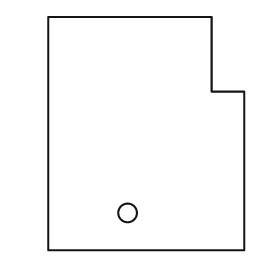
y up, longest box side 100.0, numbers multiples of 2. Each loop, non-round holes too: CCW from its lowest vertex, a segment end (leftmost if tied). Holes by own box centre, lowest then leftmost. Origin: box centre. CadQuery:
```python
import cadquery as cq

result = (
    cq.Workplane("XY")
    .moveTo(-42.0, -50.0)
    .lineTo(42.0, -50.0)
    .lineTo(42.0, 18.0)
    .lineTo(28.0, 18.0)
    .lineTo(28.0, 50.0)
    .lineTo(-42.0, 50.0)
    .close()
    .moveTo(-8.0, -34.0)
    .circle(4.0)
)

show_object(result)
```